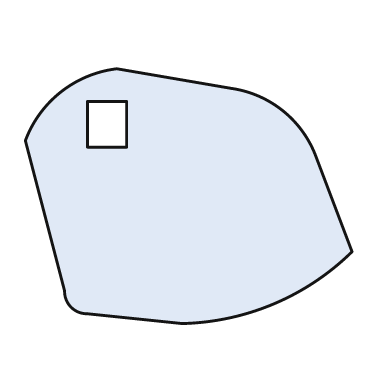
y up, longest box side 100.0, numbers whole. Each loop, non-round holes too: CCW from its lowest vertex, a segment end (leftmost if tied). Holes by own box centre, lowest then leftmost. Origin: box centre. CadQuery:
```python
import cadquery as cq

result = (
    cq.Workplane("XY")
    .moveTo(-2.0, -39.0)
    .threePointArc((26.0, -33.0), (50.0, -17.0))
    .lineTo(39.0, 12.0)
    .threePointArc((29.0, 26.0), (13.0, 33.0))
    .lineTo(-22.0, 39.0)
    .threePointArc((-39.0, 32.0), (-50.0, 17.0))
    .lineTo(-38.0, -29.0)
    .threePointArc((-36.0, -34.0), (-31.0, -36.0))
    .close()
    .moveTo(-31.0, 15.0)
    .lineTo(-19.0, 15.0)
    .lineTo(-19.0, 29.0)
    .lineTo(-31.0, 29.0)
    .close()
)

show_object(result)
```